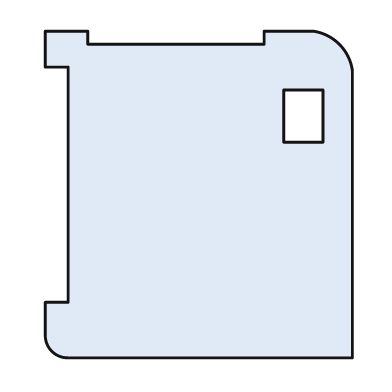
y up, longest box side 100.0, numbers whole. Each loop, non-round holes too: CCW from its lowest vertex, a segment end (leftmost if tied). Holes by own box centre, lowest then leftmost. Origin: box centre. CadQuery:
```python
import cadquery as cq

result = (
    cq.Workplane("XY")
    .moveTo(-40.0, -50.0)
    .lineTo(47.0, -50.0)
    .lineTo(47.0, 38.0)
    .threePointArc((43.0, 46.0), (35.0, 50.0))
    .lineTo(20.0, 50.0)
    .lineTo(20.0, 46.0)
    .lineTo(-34.0, 46.0)
    .lineTo(-34.0, 50.0)
    .lineTo(-47.0, 50.0)
    .lineTo(-47.0, 39.0)
    .lineTo(-40.0, 39.0)
    .lineTo(-40.0, -33.0)
    .lineTo(-47.0, -33.0)
    .lineTo(-47.0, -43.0)
    .threePointArc((-45.0, -48.0), (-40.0, -50.0))
    .close()
    .moveTo(26.0, 16.0)
    .lineTo(38.0, 16.0)
    .lineTo(38.0, 32.0)
    .lineTo(26.0, 32.0)
    .close()
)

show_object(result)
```